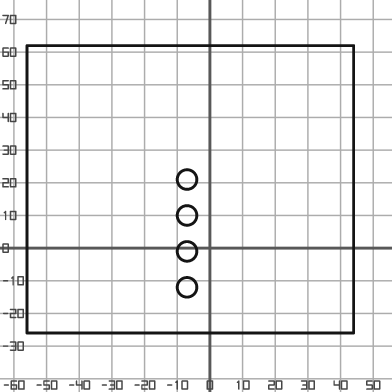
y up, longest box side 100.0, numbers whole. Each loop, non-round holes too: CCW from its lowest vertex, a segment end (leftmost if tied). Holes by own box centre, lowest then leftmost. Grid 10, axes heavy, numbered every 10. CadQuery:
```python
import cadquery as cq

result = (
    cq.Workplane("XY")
    .moveTo(-56.0, -26.0)
    .lineTo(44.0, -26.0)
    .lineTo(44.0, 62.0)
    .lineTo(-56.0, 62.0)
    .close()
    .moveTo(-7.0, -12.0)
    .circle(3.0)
    .moveTo(-7.0, -1.0)
    .circle(3.0)
    .moveTo(-7.0, 10.0)
    .circle(3.0)
    .moveTo(-7.0, 21.0)
    .circle(3.0)
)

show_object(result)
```